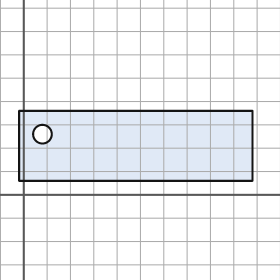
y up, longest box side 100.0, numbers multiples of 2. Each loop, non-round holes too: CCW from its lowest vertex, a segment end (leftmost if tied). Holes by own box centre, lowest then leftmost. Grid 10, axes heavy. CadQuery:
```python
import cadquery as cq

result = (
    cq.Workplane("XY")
    .moveTo(-2.0, 6.0)
    .lineTo(98.0, 6.0)
    .lineTo(98.0, 36.0)
    .lineTo(-2.0, 36.0)
    .close()
    .moveTo(8.0, 26.0)
    .circle(4.0)
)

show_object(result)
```